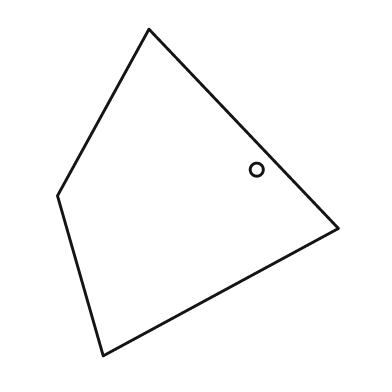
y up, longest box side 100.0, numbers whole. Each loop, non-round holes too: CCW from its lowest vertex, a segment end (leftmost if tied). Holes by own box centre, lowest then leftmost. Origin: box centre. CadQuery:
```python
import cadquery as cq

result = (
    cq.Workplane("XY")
    .moveTo(-29.0, -50.0)
    .lineTo(43.0, -11.0)
    .lineTo(-15.0, 50.0)
    .lineTo(-43.0, -1.0)
    .close()
    .moveTo(18.0, 7.0)
    .circle(2.0)
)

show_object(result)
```